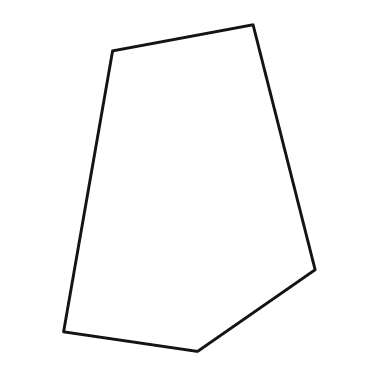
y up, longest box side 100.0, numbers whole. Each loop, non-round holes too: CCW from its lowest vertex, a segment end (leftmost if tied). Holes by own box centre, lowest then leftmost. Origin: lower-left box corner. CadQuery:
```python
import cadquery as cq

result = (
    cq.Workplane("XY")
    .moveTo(41.0, 0.0)
    .lineTo(77.0, 25.0)
    .lineTo(58.0, 100.0)
    .lineTo(15.0, 92.0)
    .lineTo(0.0, 6.0)
    .close()
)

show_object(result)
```